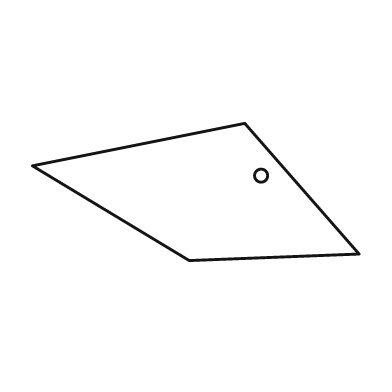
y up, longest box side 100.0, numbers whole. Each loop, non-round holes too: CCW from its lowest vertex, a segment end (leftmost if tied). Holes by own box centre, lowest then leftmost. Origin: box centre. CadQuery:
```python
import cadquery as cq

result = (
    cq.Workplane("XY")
    .moveTo(-2.0, -21.0)
    .lineTo(50.0, -19.0)
    .lineTo(15.0, 21.0)
    .lineTo(-50.0, 8.0)
    .close()
    .moveTo(20.0, 5.0)
    .circle(2.0)
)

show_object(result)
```